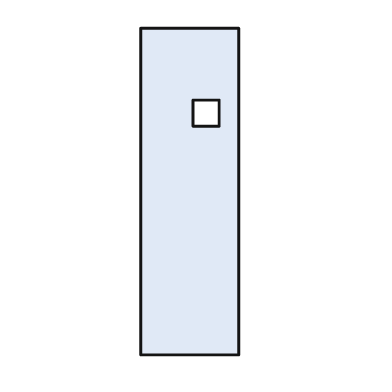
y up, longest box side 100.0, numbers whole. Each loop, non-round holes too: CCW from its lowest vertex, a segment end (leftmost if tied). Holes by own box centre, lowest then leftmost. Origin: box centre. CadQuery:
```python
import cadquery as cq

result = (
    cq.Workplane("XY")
    .moveTo(-15.0, -50.0)
    .lineTo(15.0, -50.0)
    .lineTo(15.0, 50.0)
    .lineTo(-15.0, 50.0)
    .close()
    .moveTo(1.0, 20.0)
    .lineTo(9.0, 20.0)
    .lineTo(9.0, 28.0)
    .lineTo(1.0, 28.0)
    .close()
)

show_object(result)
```